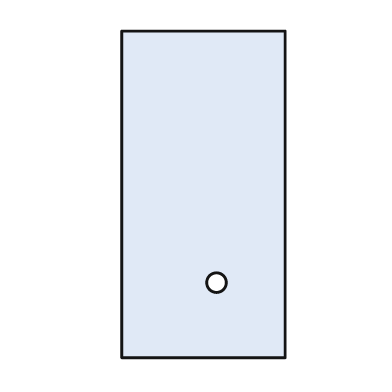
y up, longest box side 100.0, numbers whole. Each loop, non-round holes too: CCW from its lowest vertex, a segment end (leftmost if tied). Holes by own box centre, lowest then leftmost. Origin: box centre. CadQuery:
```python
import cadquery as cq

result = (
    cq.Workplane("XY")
    .moveTo(-25.0, -50.0)
    .lineTo(25.0, -50.0)
    .lineTo(25.0, 50.0)
    .lineTo(-25.0, 50.0)
    .close()
    .moveTo(4.0, -27.0)
    .circle(3.0)
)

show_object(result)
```